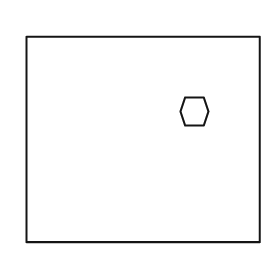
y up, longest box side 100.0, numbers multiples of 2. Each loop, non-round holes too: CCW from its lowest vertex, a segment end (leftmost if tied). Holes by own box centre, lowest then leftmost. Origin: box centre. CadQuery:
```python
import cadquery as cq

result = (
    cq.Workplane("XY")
    .moveTo(-50.0, -44.0)
    .lineTo(50.0, -44.0)
    .lineTo(50.0, 44.0)
    .lineTo(-50.0, 44.0)
    .close()
    .moveTo(18.0, 6.0)
    .lineTo(26.0, 6.0)
    .lineTo(28.0, 12.0)
    .lineTo(26.0, 18.0)
    .lineTo(18.0, 18.0)
    .lineTo(16.0, 12.0)
    .close()
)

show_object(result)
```